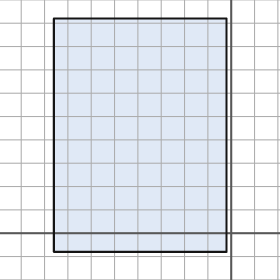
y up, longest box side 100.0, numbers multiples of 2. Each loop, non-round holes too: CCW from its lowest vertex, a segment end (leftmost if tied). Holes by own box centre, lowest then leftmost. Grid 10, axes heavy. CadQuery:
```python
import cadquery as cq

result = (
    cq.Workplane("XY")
    .moveTo(-76.0, -8.0)
    .lineTo(-2.0, -8.0)
    .lineTo(-2.0, 92.0)
    .lineTo(-76.0, 92.0)
    .close()
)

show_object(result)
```